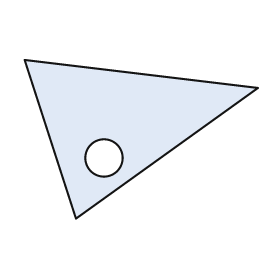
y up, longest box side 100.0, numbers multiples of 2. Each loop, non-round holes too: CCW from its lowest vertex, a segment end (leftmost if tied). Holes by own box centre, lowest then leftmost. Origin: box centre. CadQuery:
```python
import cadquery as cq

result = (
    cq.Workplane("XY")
    .moveTo(-28.0, -34.0)
    .lineTo(50.0, 22.0)
    .lineTo(-50.0, 34.0)
    .close()
    .moveTo(-16.0, -8.0)
    .circle(8.0)
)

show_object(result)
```